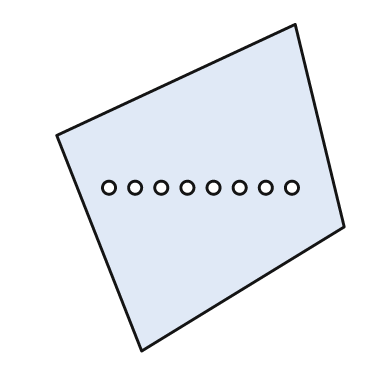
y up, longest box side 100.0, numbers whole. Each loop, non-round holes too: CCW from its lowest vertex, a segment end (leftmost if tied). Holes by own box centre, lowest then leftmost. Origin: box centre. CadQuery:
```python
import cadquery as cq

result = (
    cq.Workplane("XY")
    .moveTo(-18.0, -50.0)
    .lineTo(44.0, -12.0)
    .lineTo(29.0, 50.0)
    .lineTo(-44.0, 16.0)
    .close()
    .moveTo(-28.0, 0.0)
    .circle(2.0)
    .moveTo(-20.0, 0.0)
    .circle(2.0)
    .moveTo(-12.0, 0.0)
    .circle(2.0)
    .moveTo(-4.0, 0.0)
    .circle(2.0)
    .moveTo(4.0, 0.0)
    .circle(2.0)
    .moveTo(12.0, 0.0)
    .circle(2.0)
    .moveTo(20.0, 0.0)
    .circle(2.0)
    .moveTo(28.0, 0.0)
    .circle(2.0)
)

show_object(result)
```